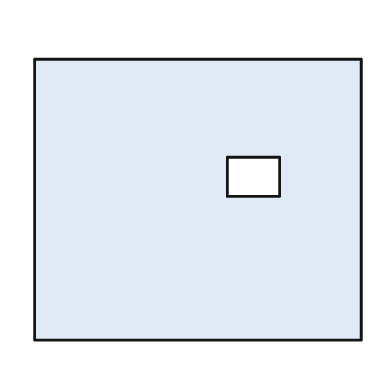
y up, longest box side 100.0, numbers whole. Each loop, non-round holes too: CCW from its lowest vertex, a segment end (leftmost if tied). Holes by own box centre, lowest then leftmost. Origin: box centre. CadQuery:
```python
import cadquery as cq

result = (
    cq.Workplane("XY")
    .moveTo(-50.0, -43.0)
    .lineTo(50.0, -43.0)
    .lineTo(50.0, 43.0)
    .lineTo(-50.0, 43.0)
    .close()
    .moveTo(9.0, 1.0)
    .lineTo(25.0, 1.0)
    .lineTo(25.0, 13.0)
    .lineTo(9.0, 13.0)
    .close()
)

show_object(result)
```